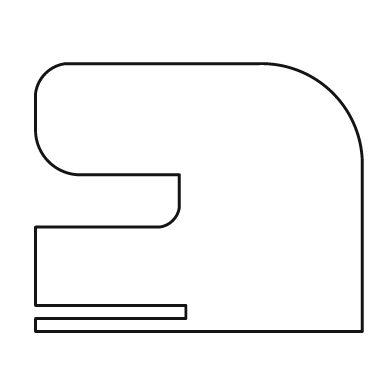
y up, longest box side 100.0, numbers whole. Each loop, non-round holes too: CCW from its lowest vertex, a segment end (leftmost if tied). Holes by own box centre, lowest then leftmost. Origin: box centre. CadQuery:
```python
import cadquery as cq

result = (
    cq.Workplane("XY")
    .moveTo(-50.0, -41.0)
    .lineTo(50.0, -41.0)
    .lineTo(50.0, 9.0)
    .threePointArc((41.0, 32.0), (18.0, 41.0))
    .lineTo(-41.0, 41.0)
    .threePointArc((-47.0, 38.0), (-50.0, 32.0))
    .lineTo(-50.0, 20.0)
    .threePointArc((-46.0, 11.0), (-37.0, 7.0))
    .lineTo(-6.0, 7.0)
    .lineTo(-6.0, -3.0)
    .threePointArc((-8.0, -7.0), (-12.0, -9.0))
    .lineTo(-50.0, -9.0)
    .lineTo(-50.0, -33.0)
    .lineTo(-4.0, -33.0)
    .lineTo(-4.0, -37.0)
    .lineTo(-50.0, -37.0)
    .close()
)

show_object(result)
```